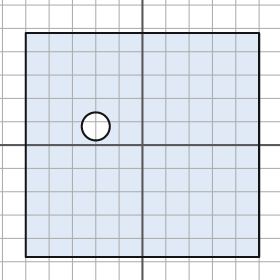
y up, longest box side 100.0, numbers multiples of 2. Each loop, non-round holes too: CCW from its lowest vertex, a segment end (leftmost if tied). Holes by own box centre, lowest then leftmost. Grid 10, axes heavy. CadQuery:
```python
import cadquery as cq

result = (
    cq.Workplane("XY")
    .moveTo(-50.0, -48.0)
    .lineTo(50.0, -48.0)
    .lineTo(50.0, 48.0)
    .lineTo(-50.0, 48.0)
    .close()
    .moveTo(-20.0, 8.0)
    .circle(6.0)
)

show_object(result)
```